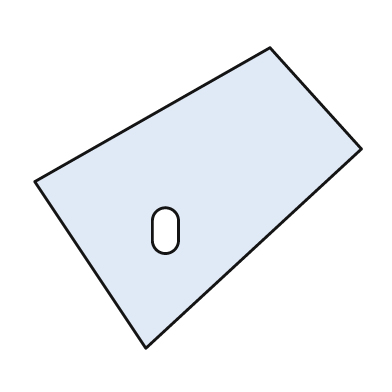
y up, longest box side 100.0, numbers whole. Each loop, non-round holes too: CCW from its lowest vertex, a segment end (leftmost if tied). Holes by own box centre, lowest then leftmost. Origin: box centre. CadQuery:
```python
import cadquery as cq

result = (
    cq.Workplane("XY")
    .moveTo(-16.0, -46.0)
    .lineTo(50.0, 15.0)
    .lineTo(22.0, 46.0)
    .lineTo(-50.0, 5.0)
    .close()
    .moveTo(-14.0, -13.0)
    .threePointArc((-10.0, -17.0), (-6.0, -13.0))
    .lineTo(-6.0, -7.0)
    .threePointArc((-10.0, -3.0), (-14.0, -7.0))
    .close()
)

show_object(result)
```